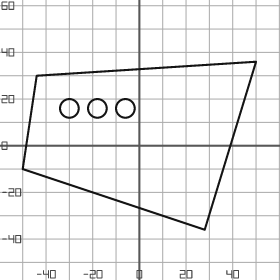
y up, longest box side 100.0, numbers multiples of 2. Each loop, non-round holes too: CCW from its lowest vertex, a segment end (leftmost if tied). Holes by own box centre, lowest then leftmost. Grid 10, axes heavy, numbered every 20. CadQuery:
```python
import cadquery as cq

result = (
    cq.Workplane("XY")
    .moveTo(28.0, -36.0)
    .lineTo(50.0, 36.0)
    .lineTo(-44.0, 30.0)
    .lineTo(-50.0, -10.0)
    .close()
    .moveTo(-30.0, 16.0)
    .circle(4.0)
    .moveTo(-18.0, 16.0)
    .circle(4.0)
    .moveTo(-6.0, 16.0)
    .circle(4.0)
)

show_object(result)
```